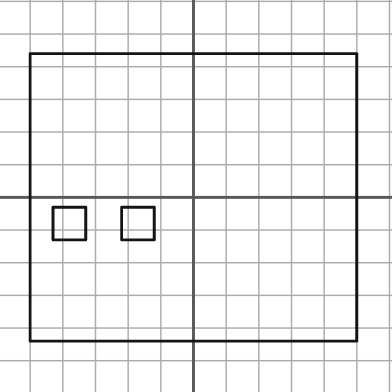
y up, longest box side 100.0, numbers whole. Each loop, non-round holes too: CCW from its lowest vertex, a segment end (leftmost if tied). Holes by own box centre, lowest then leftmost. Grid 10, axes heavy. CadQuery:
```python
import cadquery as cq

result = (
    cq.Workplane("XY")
    .moveTo(-50.0, -44.0)
    .lineTo(50.0, -44.0)
    .lineTo(50.0, 44.0)
    .lineTo(-50.0, 44.0)
    .close()
    .moveTo(-43.0, -13.0)
    .lineTo(-33.0, -13.0)
    .lineTo(-33.0, -3.0)
    .lineTo(-43.0, -3.0)
    .close()
    .moveTo(-22.0, -13.0)
    .lineTo(-12.0, -13.0)
    .lineTo(-12.0, -3.0)
    .lineTo(-22.0, -3.0)
    .close()
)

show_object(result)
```